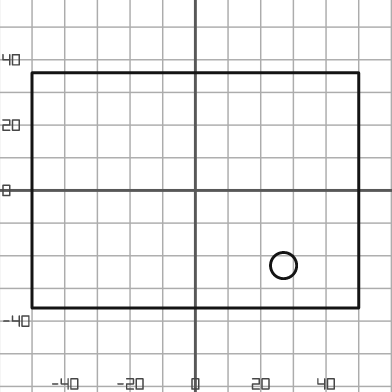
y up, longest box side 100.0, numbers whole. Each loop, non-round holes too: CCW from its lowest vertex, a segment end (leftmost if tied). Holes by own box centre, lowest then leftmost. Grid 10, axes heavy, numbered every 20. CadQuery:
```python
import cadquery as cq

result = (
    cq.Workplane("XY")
    .moveTo(-50.0, -36.0)
    .lineTo(50.0, -36.0)
    .lineTo(50.0, 36.0)
    .lineTo(-50.0, 36.0)
    .close()
    .moveTo(27.0, -23.0)
    .circle(4.0)
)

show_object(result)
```